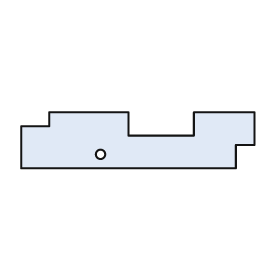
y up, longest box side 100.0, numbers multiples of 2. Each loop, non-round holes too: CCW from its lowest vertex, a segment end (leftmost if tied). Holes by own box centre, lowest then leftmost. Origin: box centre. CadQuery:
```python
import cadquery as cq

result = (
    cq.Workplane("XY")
    .moveTo(-50.0, -12.0)
    .lineTo(42.0, -12.0)
    .lineTo(42.0, -2.0)
    .lineTo(50.0, -2.0)
    .lineTo(50.0, 12.0)
    .lineTo(24.0, 12.0)
    .lineTo(24.0, 2.0)
    .lineTo(-4.0, 2.0)
    .lineTo(-4.0, 12.0)
    .lineTo(-38.0, 12.0)
    .lineTo(-38.0, 6.0)
    .lineTo(-50.0, 6.0)
    .close()
    .moveTo(-16.0, -6.0)
    .circle(2.0)
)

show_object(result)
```